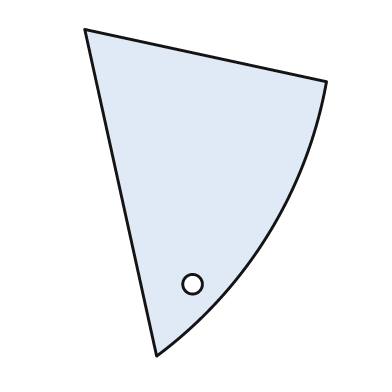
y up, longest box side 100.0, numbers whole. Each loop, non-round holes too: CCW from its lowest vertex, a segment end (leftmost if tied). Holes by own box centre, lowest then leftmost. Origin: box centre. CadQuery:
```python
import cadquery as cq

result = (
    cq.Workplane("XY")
    .moveTo(-15.0, -50.0)
    .threePointArc((19.0, -13.0), (37.0, 34.0))
    .lineTo(-37.0, 50.0)
    .close()
    .moveTo(-4.0, -28.0)
    .circle(3.0)
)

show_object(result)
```